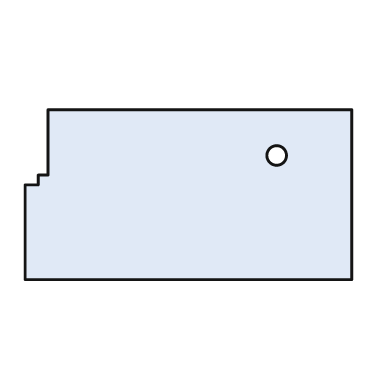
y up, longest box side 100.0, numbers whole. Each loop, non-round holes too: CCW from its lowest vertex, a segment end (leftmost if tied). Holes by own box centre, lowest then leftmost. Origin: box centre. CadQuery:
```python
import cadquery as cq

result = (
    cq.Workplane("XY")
    .moveTo(-50.0, -26.0)
    .lineTo(50.0, -26.0)
    .lineTo(50.0, 26.0)
    .lineTo(-43.0, 26.0)
    .lineTo(-43.0, 6.0)
    .lineTo(-46.0, 6.0)
    .lineTo(-46.0, 3.0)
    .lineTo(-50.0, 3.0)
    .close()
    .moveTo(27.0, 12.0)
    .circle(3.0)
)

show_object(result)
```